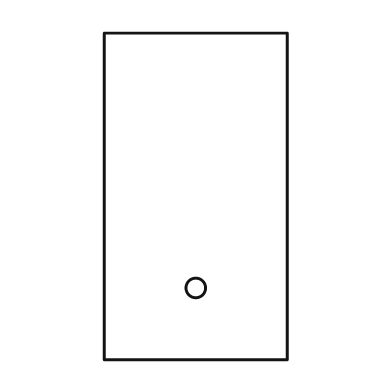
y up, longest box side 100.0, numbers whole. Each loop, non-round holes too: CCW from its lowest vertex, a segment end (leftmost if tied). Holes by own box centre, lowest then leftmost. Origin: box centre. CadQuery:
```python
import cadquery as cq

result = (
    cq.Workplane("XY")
    .moveTo(-28.0, -50.0)
    .lineTo(28.0, -50.0)
    .lineTo(28.0, 50.0)
    .lineTo(-28.0, 50.0)
    .close()
    .moveTo(0.0, -28.0)
    .circle(3.0)
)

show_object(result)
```